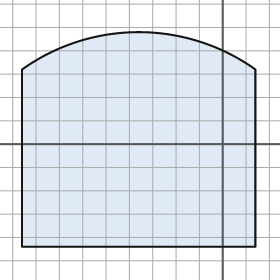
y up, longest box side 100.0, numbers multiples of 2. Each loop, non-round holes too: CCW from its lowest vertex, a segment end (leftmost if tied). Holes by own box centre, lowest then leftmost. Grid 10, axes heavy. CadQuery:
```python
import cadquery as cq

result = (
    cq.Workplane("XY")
    .moveTo(-86.0, -44.0)
    .lineTo(14.0, -44.0)
    .lineTo(14.0, 32.0)
    .threePointArc((-36.0, 48.0), (-86.0, 32.0))
    .close()
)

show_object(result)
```